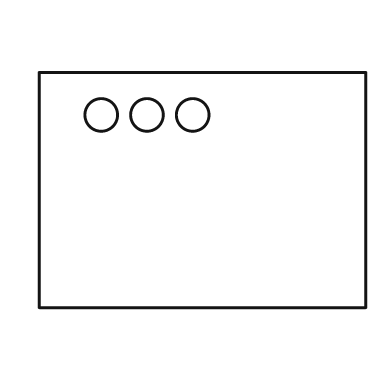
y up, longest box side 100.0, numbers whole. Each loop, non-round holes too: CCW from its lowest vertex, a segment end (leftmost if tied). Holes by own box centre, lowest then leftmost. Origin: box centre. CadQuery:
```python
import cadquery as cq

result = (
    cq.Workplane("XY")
    .moveTo(-50.0, -36.0)
    .lineTo(50.0, -36.0)
    .lineTo(50.0, 36.0)
    .lineTo(-50.0, 36.0)
    .close()
    .moveTo(-31.0, 23.0)
    .circle(5.0)
    .moveTo(-17.0, 23.0)
    .circle(5.0)
    .moveTo(-3.0, 23.0)
    .circle(5.0)
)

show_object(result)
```